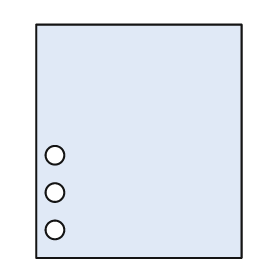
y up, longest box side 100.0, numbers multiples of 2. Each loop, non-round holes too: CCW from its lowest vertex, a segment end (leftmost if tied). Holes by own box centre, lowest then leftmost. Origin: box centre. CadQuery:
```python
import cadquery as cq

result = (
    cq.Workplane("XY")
    .moveTo(-44.0, -50.0)
    .lineTo(44.0, -50.0)
    .lineTo(44.0, 50.0)
    .lineTo(-44.0, 50.0)
    .close()
    .moveTo(-36.0, -38.0)
    .circle(4.0)
    .moveTo(-36.0, -22.0)
    .circle(4.0)
    .moveTo(-36.0, -6.0)
    .circle(4.0)
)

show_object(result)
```